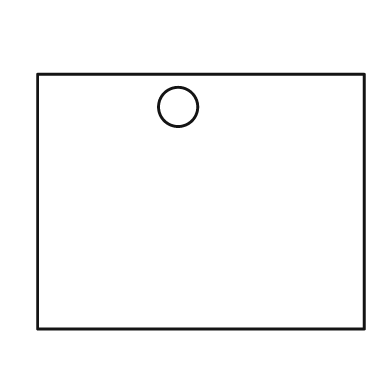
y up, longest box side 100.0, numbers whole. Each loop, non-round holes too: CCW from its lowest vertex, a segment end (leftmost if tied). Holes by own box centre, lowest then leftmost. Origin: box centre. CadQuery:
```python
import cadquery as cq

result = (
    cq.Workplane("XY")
    .moveTo(-50.0, -39.0)
    .lineTo(50.0, -39.0)
    .lineTo(50.0, 39.0)
    .lineTo(-50.0, 39.0)
    .close()
    .moveTo(-7.0, 29.0)
    .circle(6.0)
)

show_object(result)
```